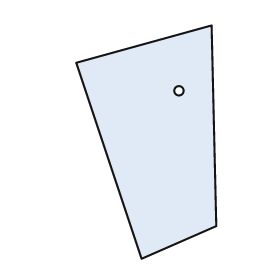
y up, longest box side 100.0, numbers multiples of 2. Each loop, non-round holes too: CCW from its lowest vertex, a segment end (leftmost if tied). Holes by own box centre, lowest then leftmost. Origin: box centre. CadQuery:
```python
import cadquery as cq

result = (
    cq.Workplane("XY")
    .moveTo(-2.0, -50.0)
    .lineTo(30.0, -36.0)
    .lineTo(28.0, 50.0)
    .lineTo(-30.0, 34.0)
    .close()
    .moveTo(14.0, 22.0)
    .circle(2.0)
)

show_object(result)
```